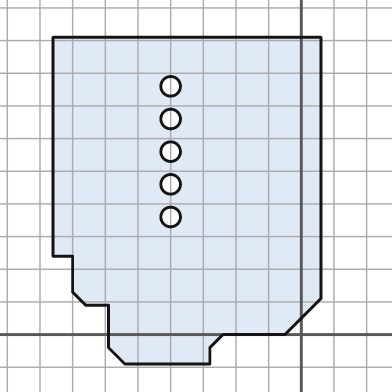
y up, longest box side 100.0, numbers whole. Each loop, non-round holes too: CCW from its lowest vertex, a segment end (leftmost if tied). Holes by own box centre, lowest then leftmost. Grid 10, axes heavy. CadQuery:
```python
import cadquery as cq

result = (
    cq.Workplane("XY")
    .moveTo(-54.0, -9.0)
    .lineTo(-28.0, -9.0)
    .lineTo(-28.0, -4.0)
    .lineTo(-24.0, 0.0)
    .lineTo(-5.0, 0.0)
    .lineTo(6.0, 11.0)
    .lineTo(6.0, 91.0)
    .lineTo(-76.0, 91.0)
    .lineTo(-76.0, 24.0)
    .lineTo(-70.0, 24.0)
    .lineTo(-70.0, 13.0)
    .lineTo(-66.0, 9.0)
    .lineTo(-59.0, 9.0)
    .lineTo(-59.0, -4.0)
    .close()
    .moveTo(-40.0, 36.0)
    .circle(3.0)
    .moveTo(-40.0, 46.0)
    .circle(3.0)
    .moveTo(-40.0, 56.0)
    .circle(3.0)
    .moveTo(-40.0, 66.0)
    .circle(3.0)
    .moveTo(-40.0, 76.0)
    .circle(3.0)
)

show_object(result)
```